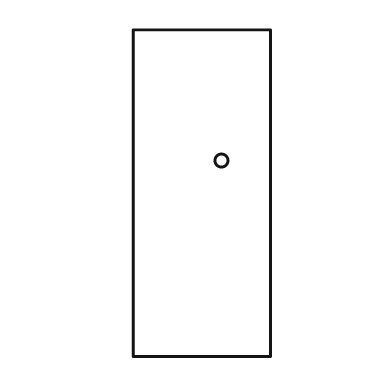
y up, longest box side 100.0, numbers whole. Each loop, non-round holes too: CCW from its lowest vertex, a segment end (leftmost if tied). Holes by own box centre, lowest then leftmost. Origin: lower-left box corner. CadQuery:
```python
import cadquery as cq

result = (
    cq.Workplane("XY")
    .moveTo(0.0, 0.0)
    .lineTo(42.0, 0.0)
    .lineTo(42.0, 100.0)
    .lineTo(0.0, 100.0)
    .close()
    .moveTo(27.0, 60.0)
    .circle(2.0)
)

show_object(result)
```